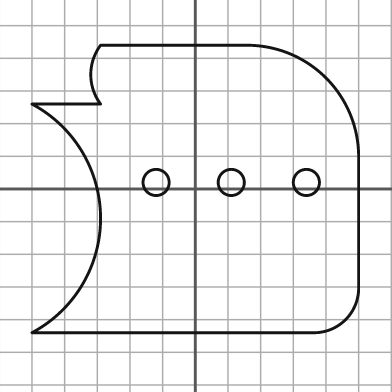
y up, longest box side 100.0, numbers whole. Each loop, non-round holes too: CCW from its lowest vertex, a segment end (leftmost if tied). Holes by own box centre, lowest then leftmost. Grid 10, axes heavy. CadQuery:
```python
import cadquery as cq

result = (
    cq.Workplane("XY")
    .moveTo(-50.0, -44.0)
    .lineTo(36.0, -44.0)
    .threePointArc((46.0, -40.0), (50.0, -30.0))
    .lineTo(50.0, 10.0)
    .threePointArc((40.0, 34.0), (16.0, 44.0))
    .lineTo(-29.0, 44.0)
    .threePointArc((-32.0, 35.0), (-29.0, 26.0))
    .lineTo(-50.0, 26.0)
    .threePointArc((-29.0, -9.0), (-50.0, -44.0))
    .close()
    .moveTo(-12.0, 2.0)
    .circle(4.0)
    .moveTo(11.0, 2.0)
    .circle(4.0)
    .moveTo(34.0, 2.0)
    .circle(4.0)
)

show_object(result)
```